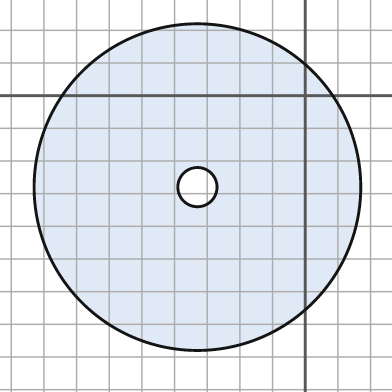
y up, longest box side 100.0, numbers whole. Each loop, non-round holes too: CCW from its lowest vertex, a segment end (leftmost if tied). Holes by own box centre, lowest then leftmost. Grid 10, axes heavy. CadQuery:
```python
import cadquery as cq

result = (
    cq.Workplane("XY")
    .moveTo(-33.0, -28.0)
    .circle(50.0)
    .moveTo(-33.0, -28.0)
    .circle(6.0)
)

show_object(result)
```